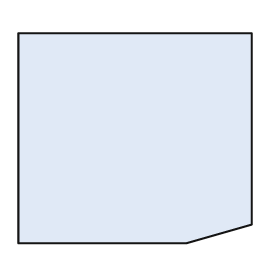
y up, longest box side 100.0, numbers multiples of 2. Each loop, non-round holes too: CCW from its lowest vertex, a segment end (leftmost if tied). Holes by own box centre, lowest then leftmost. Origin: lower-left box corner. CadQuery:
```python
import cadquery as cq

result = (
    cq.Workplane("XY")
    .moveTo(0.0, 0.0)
    .lineTo(72.0, 0.0)
    .lineTo(100.0, 8.0)
    .lineTo(100.0, 90.0)
    .lineTo(0.0, 90.0)
    .close()
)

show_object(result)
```